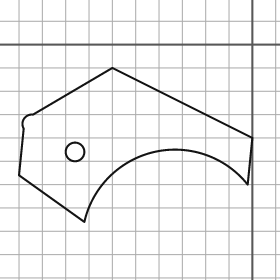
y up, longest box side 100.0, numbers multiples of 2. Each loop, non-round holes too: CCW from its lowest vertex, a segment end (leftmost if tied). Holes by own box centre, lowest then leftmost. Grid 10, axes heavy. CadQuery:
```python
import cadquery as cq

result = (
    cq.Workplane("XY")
    .moveTo(-72.0, -76.0)
    .threePointArc((-42.0, -46.0), (-2.0, -60.0))
    .lineTo(0.0, -40.0)
    .lineTo(-60.0, -10.0)
    .lineTo(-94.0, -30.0)
    .threePointArc((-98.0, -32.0), (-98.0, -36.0))
    .lineTo(-100.0, -56.0)
    .close()
    .moveTo(-76.0, -46.0)
    .circle(4.0)
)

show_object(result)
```